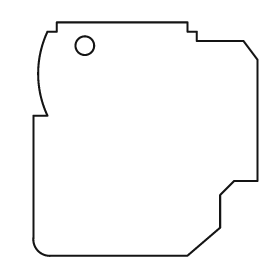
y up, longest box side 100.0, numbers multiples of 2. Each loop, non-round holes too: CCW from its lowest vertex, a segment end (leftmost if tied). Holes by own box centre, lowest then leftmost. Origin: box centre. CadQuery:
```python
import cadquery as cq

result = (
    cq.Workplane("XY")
    .moveTo(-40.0, -50.0)
    .lineTo(18.0, -50.0)
    .lineTo(32.0, -38.0)
    .lineTo(32.0, -24.0)
    .lineTo(38.0, -18.0)
    .lineTo(48.0, -18.0)
    .lineTo(48.0, 34.0)
    .lineTo(42.0, 42.0)
    .lineTo(22.0, 42.0)
    .lineTo(22.0, 46.0)
    .lineTo(18.0, 46.0)
    .lineTo(18.0, 50.0)
    .lineTo(-38.0, 50.0)
    .lineTo(-38.0, 46.0)
    .lineTo(-42.0, 46.0)
    .threePointArc((-46.0, 28.0), (-42.0, 10.0))
    .lineTo(-48.0, 10.0)
    .lineTo(-48.0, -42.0)
    .threePointArc((-46.0, -48.0), (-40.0, -50.0))
    .close()
    .moveTo(-26.0, 40.0)
    .circle(4.0)
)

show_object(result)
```